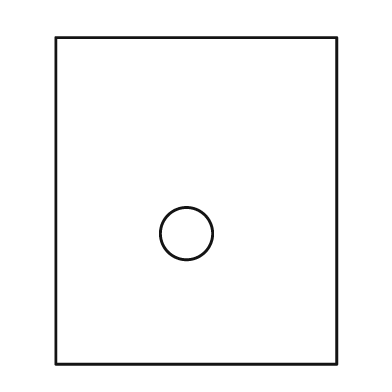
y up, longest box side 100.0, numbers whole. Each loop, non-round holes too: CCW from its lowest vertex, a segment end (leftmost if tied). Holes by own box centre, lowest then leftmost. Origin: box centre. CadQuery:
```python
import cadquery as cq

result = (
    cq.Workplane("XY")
    .moveTo(-43.0, -50.0)
    .lineTo(43.0, -50.0)
    .lineTo(43.0, 50.0)
    .lineTo(-43.0, 50.0)
    .close()
    .moveTo(-3.0, -10.0)
    .circle(8.0)
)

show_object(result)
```